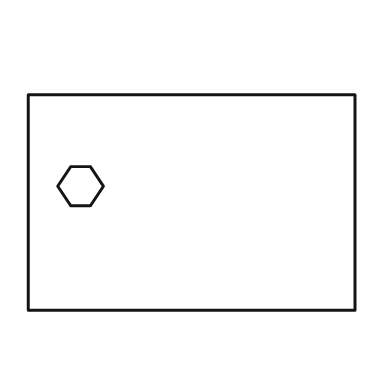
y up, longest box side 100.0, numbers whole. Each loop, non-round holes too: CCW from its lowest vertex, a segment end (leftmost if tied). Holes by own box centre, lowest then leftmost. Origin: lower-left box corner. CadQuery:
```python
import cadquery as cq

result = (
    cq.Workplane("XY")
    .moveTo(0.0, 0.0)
    .lineTo(100.0, 0.0)
    .lineTo(100.0, 66.0)
    .lineTo(0.0, 66.0)
    .close()
    .moveTo(13.0, 32.0)
    .lineTo(19.0, 32.0)
    .lineTo(23.0, 38.0)
    .lineTo(19.0, 44.0)
    .lineTo(13.0, 44.0)
    .lineTo(9.0, 38.0)
    .close()
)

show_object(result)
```